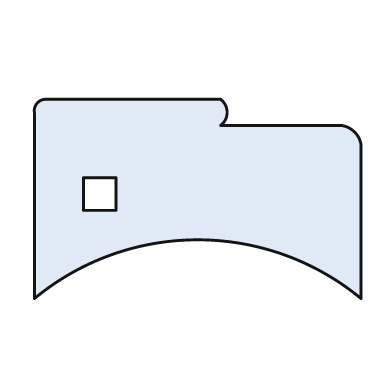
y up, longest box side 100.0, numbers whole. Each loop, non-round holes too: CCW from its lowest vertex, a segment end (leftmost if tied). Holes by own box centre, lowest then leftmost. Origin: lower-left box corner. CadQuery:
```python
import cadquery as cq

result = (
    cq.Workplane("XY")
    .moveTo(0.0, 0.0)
    .threePointArc((50.0, 18.0), (100.0, 0.0))
    .lineTo(100.0, 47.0)
    .threePointArc((98.0, 51.0), (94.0, 53.0))
    .lineTo(57.0, 53.0)
    .threePointArc((59.0, 57.0), (57.0, 61.0))
    .lineTo(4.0, 61.0)
    .threePointArc((1.0, 60.0), (0.0, 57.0))
    .close()
    .moveTo(15.0, 27.0)
    .lineTo(25.0, 27.0)
    .lineTo(25.0, 37.0)
    .lineTo(15.0, 37.0)
    .close()
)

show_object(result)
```